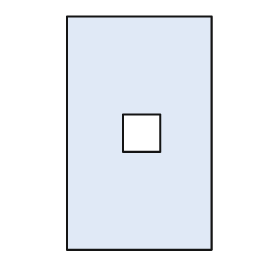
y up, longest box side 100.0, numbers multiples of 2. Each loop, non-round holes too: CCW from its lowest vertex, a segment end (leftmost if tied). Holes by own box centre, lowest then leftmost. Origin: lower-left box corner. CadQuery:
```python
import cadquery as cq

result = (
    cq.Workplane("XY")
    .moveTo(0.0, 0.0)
    .lineTo(62.0, 0.0)
    .lineTo(62.0, 100.0)
    .lineTo(0.0, 100.0)
    .close()
    .moveTo(24.0, 42.0)
    .lineTo(40.0, 42.0)
    .lineTo(40.0, 58.0)
    .lineTo(24.0, 58.0)
    .close()
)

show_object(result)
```